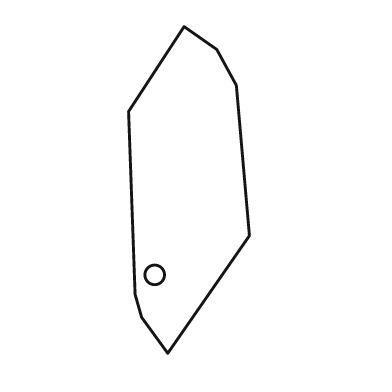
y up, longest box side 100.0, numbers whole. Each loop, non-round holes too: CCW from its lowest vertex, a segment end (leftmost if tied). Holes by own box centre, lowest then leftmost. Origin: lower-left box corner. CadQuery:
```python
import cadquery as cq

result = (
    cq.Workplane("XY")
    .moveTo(12.0, 0.0)
    .lineTo(37.0, 36.0)
    .lineTo(33.0, 82.0)
    .lineTo(27.0, 93.0)
    .lineTo(17.0, 100.0)
    .lineTo(0.0, 74.0)
    .lineTo(2.0, 18.0)
    .lineTo(4.0, 11.0)
    .close()
    .moveTo(8.0, 24.0)
    .circle(3.0)
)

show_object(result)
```